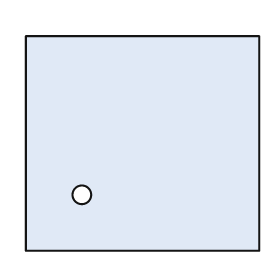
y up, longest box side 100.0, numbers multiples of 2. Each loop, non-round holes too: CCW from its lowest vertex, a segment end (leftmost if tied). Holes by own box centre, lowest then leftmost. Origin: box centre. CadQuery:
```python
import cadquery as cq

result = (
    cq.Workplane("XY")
    .moveTo(-50.0, -46.0)
    .lineTo(50.0, -46.0)
    .lineTo(50.0, 46.0)
    .lineTo(-50.0, 46.0)
    .close()
    .moveTo(-26.0, -22.0)
    .circle(4.0)
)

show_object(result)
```